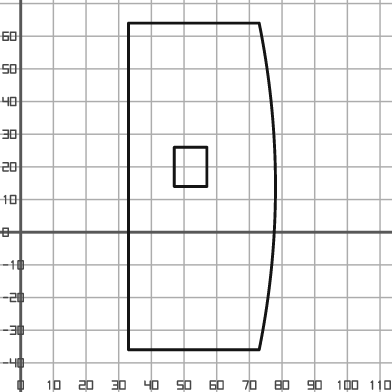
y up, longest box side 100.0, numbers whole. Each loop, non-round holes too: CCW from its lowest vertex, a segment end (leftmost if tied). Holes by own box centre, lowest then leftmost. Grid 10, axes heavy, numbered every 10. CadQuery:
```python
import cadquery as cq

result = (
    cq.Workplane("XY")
    .moveTo(33.0, -36.0)
    .lineTo(73.0, -36.0)
    .threePointArc((78.0, 14.0), (73.0, 64.0))
    .lineTo(33.0, 64.0)
    .close()
    .moveTo(47.0, 14.0)
    .lineTo(57.0, 14.0)
    .lineTo(57.0, 26.0)
    .lineTo(47.0, 26.0)
    .close()
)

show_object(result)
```